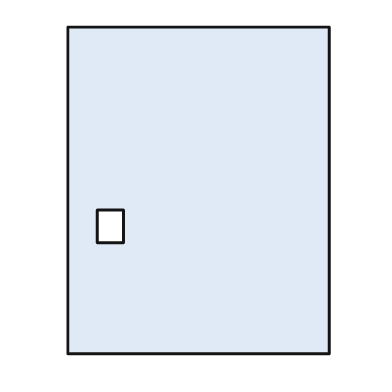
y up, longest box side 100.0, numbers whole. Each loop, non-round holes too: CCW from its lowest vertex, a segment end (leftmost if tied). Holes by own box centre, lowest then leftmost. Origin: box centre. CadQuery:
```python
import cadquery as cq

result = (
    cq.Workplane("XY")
    .moveTo(-40.0, -50.0)
    .lineTo(40.0, -50.0)
    .lineTo(40.0, 50.0)
    .lineTo(-40.0, 50.0)
    .close()
    .moveTo(-31.0, -16.0)
    .lineTo(-23.0, -16.0)
    .lineTo(-23.0, -6.0)
    .lineTo(-31.0, -6.0)
    .close()
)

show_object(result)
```